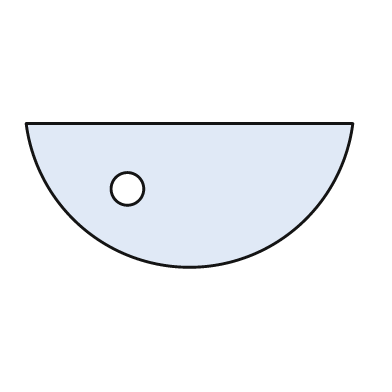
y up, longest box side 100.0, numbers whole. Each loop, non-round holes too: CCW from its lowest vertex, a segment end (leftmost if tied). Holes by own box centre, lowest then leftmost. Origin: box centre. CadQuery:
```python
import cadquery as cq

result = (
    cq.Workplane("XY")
    .moveTo(-50.0, 22.0)
    .threePointArc((0.0, -22.0), (50.0, 22.0))
    .close()
    .moveTo(-19.0, 2.0)
    .circle(5.0)
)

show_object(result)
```